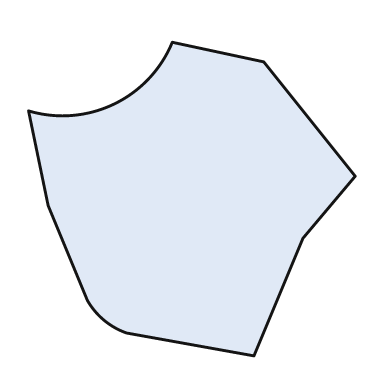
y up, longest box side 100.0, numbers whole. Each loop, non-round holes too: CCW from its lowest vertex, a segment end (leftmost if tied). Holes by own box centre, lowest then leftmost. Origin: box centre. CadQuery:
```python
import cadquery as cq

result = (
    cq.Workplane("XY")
    .moveTo(19.0, -48.0)
    .lineTo(34.0, -12.0)
    .lineTo(50.0, 7.0)
    .lineTo(22.0, 42.0)
    .lineTo(-6.0, 48.0)
    .threePointArc((-24.0, 29.0), (-50.0, 27.0))
    .lineTo(-44.0, -2.0)
    .lineTo(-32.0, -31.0)
    .threePointArc((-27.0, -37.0), (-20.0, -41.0))
    .close()
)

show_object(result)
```